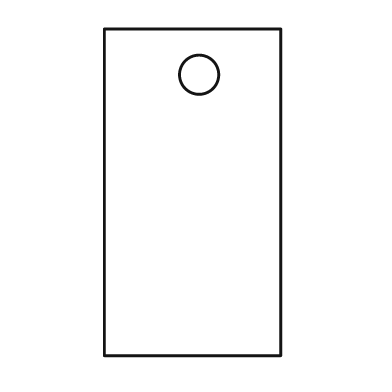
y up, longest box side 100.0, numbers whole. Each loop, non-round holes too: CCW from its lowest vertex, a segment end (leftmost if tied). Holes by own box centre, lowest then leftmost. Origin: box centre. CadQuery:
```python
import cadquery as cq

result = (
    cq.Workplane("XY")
    .moveTo(-27.0, -50.0)
    .lineTo(27.0, -50.0)
    .lineTo(27.0, 50.0)
    .lineTo(-27.0, 50.0)
    .close()
    .moveTo(2.0, 36.0)
    .circle(6.0)
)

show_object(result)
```